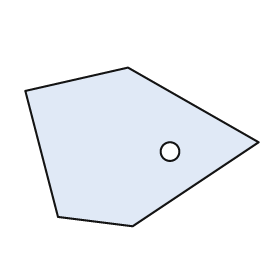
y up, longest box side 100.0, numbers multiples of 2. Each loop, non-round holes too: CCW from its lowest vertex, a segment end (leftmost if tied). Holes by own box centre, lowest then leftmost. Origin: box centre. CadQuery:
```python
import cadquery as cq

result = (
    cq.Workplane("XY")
    .moveTo(-4.0, -34.0)
    .lineTo(50.0, 2.0)
    .lineTo(-6.0, 34.0)
    .lineTo(-50.0, 24.0)
    .lineTo(-36.0, -30.0)
    .close()
    .moveTo(12.0, -2.0)
    .circle(4.0)
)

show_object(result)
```